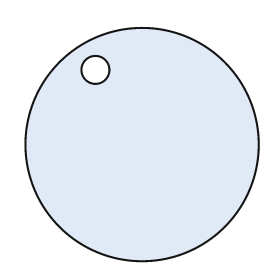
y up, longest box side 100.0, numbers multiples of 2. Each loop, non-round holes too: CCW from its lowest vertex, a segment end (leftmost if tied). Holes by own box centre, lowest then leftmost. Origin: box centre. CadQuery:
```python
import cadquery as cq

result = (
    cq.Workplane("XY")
    .moveTo(0.0, 0.0)
    .circle(50.0)
    .moveTo(-20.0, 32.0)
    .circle(6.0)
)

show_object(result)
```